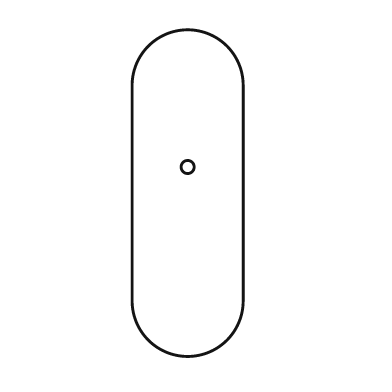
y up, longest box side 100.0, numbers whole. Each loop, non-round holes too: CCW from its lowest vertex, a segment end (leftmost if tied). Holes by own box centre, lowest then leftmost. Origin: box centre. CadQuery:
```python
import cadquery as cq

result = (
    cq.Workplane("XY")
    .moveTo(-17.0, -33.0)
    .threePointArc((0.0, -50.0), (17.0, -33.0))
    .lineTo(17.0, 33.0)
    .threePointArc((0.0, 50.0), (-17.0, 33.0))
    .close()
    .moveTo(0.0, 8.0)
    .circle(2.0)
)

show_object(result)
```